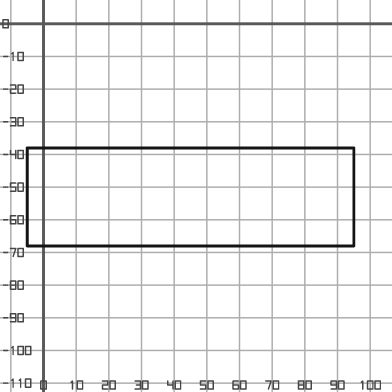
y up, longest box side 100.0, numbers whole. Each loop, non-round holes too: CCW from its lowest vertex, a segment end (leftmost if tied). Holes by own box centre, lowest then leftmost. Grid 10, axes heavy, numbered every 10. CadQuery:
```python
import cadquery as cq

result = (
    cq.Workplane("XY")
    .moveTo(-5.0, -68.0)
    .lineTo(95.0, -68.0)
    .lineTo(95.0, -38.0)
    .lineTo(-5.0, -38.0)
    .close()
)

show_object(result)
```